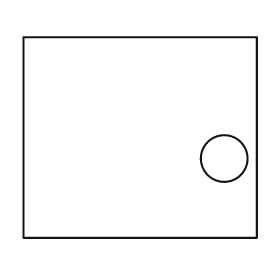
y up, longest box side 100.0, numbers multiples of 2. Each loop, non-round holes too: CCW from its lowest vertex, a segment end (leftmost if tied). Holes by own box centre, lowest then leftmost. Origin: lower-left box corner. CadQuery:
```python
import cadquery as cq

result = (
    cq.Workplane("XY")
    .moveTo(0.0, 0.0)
    .lineTo(100.0, 0.0)
    .lineTo(100.0, 86.0)
    .lineTo(0.0, 86.0)
    .close()
    .moveTo(86.0, 34.0)
    .circle(10.0)
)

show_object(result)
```